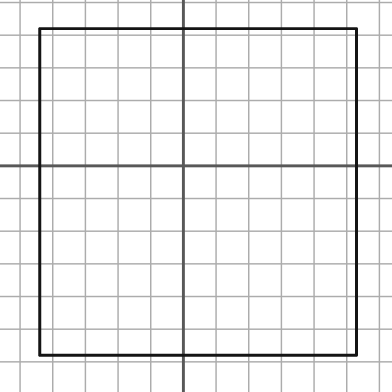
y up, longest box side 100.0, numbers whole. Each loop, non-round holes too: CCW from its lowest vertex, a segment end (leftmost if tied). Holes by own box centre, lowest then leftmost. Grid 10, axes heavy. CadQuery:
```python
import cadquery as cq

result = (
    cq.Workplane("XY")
    .moveTo(-44.0, -58.0)
    .lineTo(53.0, -58.0)
    .lineTo(53.0, 42.0)
    .lineTo(-44.0, 42.0)
    .close()
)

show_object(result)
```